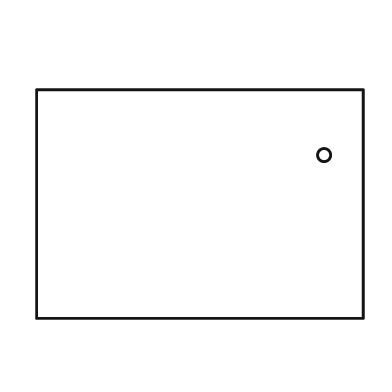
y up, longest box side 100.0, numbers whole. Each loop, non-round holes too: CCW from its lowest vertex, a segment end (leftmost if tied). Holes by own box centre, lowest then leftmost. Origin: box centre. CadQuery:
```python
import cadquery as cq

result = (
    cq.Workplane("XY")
    .moveTo(-50.0, -35.0)
    .lineTo(50.0, -35.0)
    .lineTo(50.0, 35.0)
    .lineTo(-50.0, 35.0)
    .close()
    .moveTo(38.0, 15.0)
    .circle(2.0)
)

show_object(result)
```